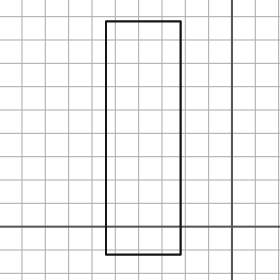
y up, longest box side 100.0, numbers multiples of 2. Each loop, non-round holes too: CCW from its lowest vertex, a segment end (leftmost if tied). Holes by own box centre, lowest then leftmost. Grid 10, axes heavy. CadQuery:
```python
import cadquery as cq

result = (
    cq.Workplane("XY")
    .moveTo(-54.0, -12.0)
    .lineTo(-22.0, -12.0)
    .lineTo(-22.0, 88.0)
    .lineTo(-54.0, 88.0)
    .close()
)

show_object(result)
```